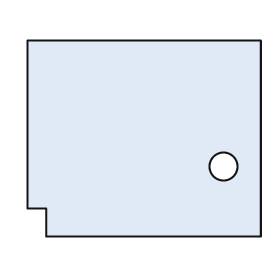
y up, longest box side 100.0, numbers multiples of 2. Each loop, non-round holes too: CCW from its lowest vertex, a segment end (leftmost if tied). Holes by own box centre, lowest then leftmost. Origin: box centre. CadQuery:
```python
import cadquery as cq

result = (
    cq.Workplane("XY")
    .moveTo(-42.0, -42.0)
    .lineTo(50.0, -42.0)
    .lineTo(50.0, 42.0)
    .lineTo(-50.0, 42.0)
    .lineTo(-50.0, -30.0)
    .lineTo(-42.0, -30.0)
    .close()
    .moveTo(34.0, -12.0)
    .circle(6.0)
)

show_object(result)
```